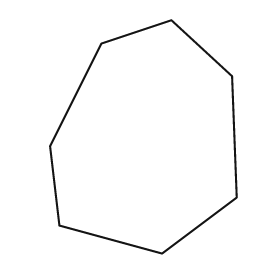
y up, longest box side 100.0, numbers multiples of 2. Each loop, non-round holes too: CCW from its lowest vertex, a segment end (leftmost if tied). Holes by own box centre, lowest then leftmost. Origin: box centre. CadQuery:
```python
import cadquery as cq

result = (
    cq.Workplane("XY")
    .moveTo(8.0, -50.0)
    .lineTo(40.0, -26.0)
    .lineTo(38.0, 26.0)
    .lineTo(12.0, 50.0)
    .lineTo(-18.0, 40.0)
    .lineTo(-40.0, -4.0)
    .lineTo(-36.0, -38.0)
    .close()
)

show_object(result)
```